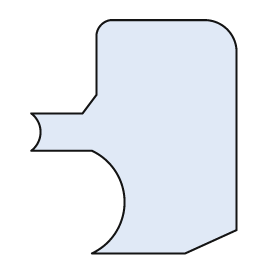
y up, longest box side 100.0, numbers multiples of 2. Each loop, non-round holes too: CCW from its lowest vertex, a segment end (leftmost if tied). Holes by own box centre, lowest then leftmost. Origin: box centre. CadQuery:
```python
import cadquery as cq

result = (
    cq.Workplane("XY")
    .moveTo(-18.0, -50.0)
    .lineTo(22.0, -50.0)
    .lineTo(44.0, -40.0)
    .lineTo(44.0, 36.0)
    .threePointArc((40.0, 46.0), (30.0, 50.0))
    .lineTo(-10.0, 50.0)
    .threePointArc((-14.0, 48.0), (-16.0, 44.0))
    .lineTo(-16.0, 18.0)
    .lineTo(-22.0, 10.0)
    .lineTo(-44.0, 10.0)
    .threePointArc((-40.0, 2.0), (-44.0, -6.0))
    .lineTo(-18.0, -6.0)
    .threePointArc((-4.0, -28.0), (-18.0, -50.0))
    .close()
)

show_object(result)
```